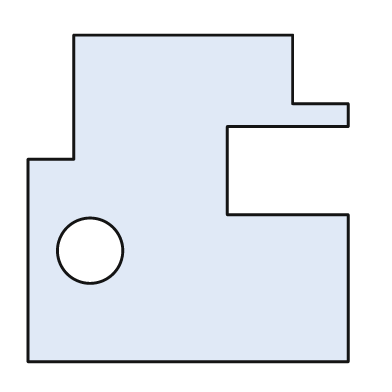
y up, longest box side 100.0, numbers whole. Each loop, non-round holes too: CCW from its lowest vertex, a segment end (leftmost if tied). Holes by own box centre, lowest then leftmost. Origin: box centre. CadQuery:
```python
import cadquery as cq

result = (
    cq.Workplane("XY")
    .moveTo(-49.0, -50.0)
    .lineTo(49.0, -50.0)
    .lineTo(49.0, -5.0)
    .lineTo(12.0, -5.0)
    .lineTo(12.0, 22.0)
    .lineTo(49.0, 22.0)
    .lineTo(49.0, 29.0)
    .lineTo(32.0, 29.0)
    .lineTo(32.0, 50.0)
    .lineTo(-35.0, 50.0)
    .lineTo(-35.0, 12.0)
    .lineTo(-49.0, 12.0)
    .close()
    .moveTo(-30.0, -16.0)
    .circle(10.0)
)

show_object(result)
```